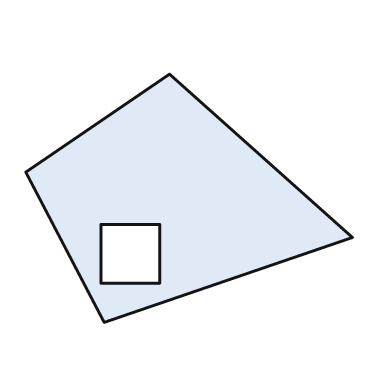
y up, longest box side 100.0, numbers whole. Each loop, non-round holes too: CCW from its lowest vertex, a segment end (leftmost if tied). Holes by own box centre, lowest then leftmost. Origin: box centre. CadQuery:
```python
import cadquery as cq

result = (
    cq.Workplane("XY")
    .moveTo(-26.0, -38.0)
    .lineTo(50.0, -12.0)
    .lineTo(-6.0, 38.0)
    .lineTo(-50.0, 8.0)
    .close()
    .moveTo(-27.0, -26.0)
    .lineTo(-9.0, -26.0)
    .lineTo(-9.0, -8.0)
    .lineTo(-27.0, -8.0)
    .close()
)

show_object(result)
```